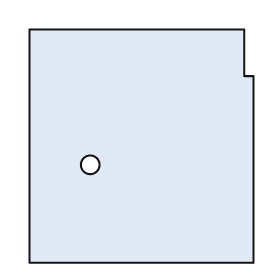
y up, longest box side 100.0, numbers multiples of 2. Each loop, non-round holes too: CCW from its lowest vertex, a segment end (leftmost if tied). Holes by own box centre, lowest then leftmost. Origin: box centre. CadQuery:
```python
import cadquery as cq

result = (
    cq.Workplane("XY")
    .moveTo(-48.0, -50.0)
    .lineTo(48.0, -50.0)
    .lineTo(48.0, 30.0)
    .lineTo(44.0, 30.0)
    .lineTo(44.0, 50.0)
    .lineTo(-48.0, 50.0)
    .close()
    .moveTo(-22.0, -8.0)
    .circle(4.0)
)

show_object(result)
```